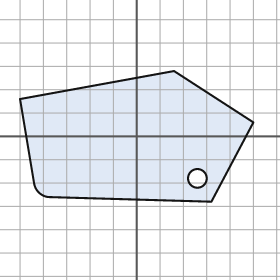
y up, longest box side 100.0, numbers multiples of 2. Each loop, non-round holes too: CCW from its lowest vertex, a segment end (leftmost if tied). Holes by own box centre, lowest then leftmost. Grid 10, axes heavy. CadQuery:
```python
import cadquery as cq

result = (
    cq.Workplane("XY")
    .moveTo(32.0, -28.0)
    .lineTo(50.0, 6.0)
    .lineTo(16.0, 28.0)
    .lineTo(-50.0, 16.0)
    .lineTo(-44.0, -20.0)
    .threePointArc((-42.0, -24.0), (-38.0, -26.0))
    .close()
    .moveTo(26.0, -18.0)
    .circle(4.0)
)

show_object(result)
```